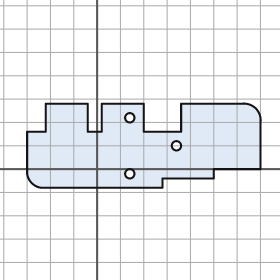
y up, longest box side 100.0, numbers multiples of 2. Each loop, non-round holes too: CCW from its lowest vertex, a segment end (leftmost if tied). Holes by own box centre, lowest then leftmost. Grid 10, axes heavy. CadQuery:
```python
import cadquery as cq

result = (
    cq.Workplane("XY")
    .moveTo(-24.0, -8.0)
    .lineTo(28.0, -8.0)
    .lineTo(28.0, -4.0)
    .lineTo(50.0, -4.0)
    .lineTo(50.0, 0.0)
    .lineTo(70.0, 0.0)
    .lineTo(70.0, 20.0)
    .threePointArc((68.0, 26.0), (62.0, 28.0))
    .lineTo(36.0, 28.0)
    .lineTo(36.0, 16.0)
    .lineTo(20.0, 16.0)
    .lineTo(20.0, 28.0)
    .lineTo(2.0, 28.0)
    .lineTo(2.0, 16.0)
    .lineTo(-4.0, 16.0)
    .lineTo(-4.0, 28.0)
    .lineTo(-22.0, 28.0)
    .lineTo(-22.0, 16.0)
    .lineTo(-30.0, 16.0)
    .lineTo(-30.0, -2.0)
    .threePointArc((-28.0, -6.0), (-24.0, -8.0))
    .close()
    .moveTo(14.0, -2.0)
    .circle(2.0)
    .moveTo(34.0, 10.0)
    .circle(2.0)
    .moveTo(14.0, 22.0)
    .circle(2.0)
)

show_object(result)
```